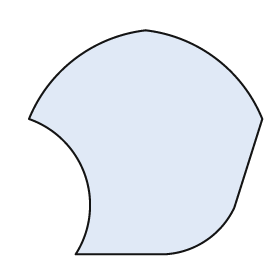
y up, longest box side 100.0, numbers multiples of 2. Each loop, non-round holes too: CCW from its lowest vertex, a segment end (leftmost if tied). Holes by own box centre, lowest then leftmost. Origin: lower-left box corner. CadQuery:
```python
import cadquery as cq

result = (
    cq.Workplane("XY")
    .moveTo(20.0, 0.0)
    .lineTo(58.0, 0.0)
    .threePointArc((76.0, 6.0), (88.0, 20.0))
    .lineTo(100.0, 58.0)
    .threePointArc((80.0, 84.0), (50.0, 96.0))
    .threePointArc((20.0, 84.0), (0.0, 58.0))
    .threePointArc((24.0, 34.0), (20.0, 0.0))
    .close()
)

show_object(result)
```